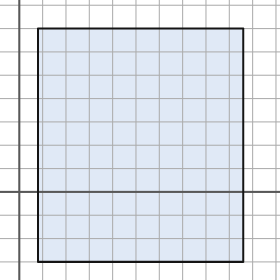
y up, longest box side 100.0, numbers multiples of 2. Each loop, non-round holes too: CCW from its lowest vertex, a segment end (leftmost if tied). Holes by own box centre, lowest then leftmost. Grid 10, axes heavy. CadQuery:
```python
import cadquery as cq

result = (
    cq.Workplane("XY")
    .moveTo(8.0, -30.0)
    .lineTo(96.0, -30.0)
    .lineTo(96.0, 70.0)
    .lineTo(8.0, 70.0)
    .close()
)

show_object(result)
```